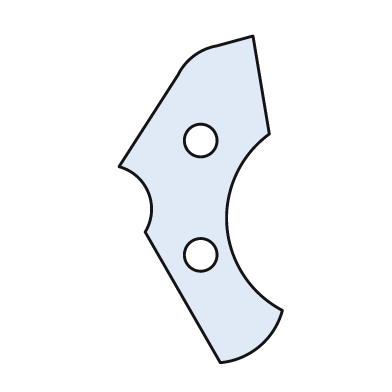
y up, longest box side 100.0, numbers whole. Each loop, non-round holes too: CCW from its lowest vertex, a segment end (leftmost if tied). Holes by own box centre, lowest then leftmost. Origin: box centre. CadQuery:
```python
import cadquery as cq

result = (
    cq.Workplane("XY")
    .moveTo(6.0, -50.0)
    .threePointArc((18.0, -45.0), (25.0, -34.0))
    .threePointArc((8.0, -8.0), (21.0, 20.0))
    .lineTo(16.0, 50.0)
    .lineTo(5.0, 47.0)
    .threePointArc((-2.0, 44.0), (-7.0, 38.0))
    .lineTo(-25.0, 10.0)
    .threePointArc((-16.0, 2.0), (-17.0, -10.0))
    .close()
    .moveTo(0.0, -17.0)
    .circle(5.0)
    .moveTo(0.0, 18.0)
    .circle(5.0)
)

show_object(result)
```